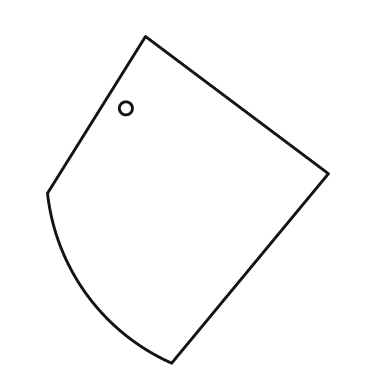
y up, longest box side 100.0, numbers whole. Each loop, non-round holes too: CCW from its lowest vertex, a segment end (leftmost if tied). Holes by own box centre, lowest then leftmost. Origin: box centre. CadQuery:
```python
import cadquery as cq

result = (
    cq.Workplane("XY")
    .moveTo(-5.0, -50.0)
    .lineTo(43.0, 8.0)
    .lineTo(-13.0, 50.0)
    .lineTo(-43.0, 2.0)
    .threePointArc((-31.0, -29.0), (-5.0, -50.0))
    .close()
    .moveTo(-19.0, 28.0)
    .circle(2.0)
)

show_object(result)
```